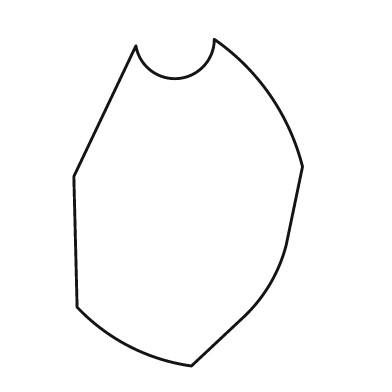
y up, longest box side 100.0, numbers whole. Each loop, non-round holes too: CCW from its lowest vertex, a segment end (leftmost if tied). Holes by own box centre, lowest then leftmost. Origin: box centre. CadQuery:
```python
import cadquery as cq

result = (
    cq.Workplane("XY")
    .moveTo(1.0, -50.0)
    .lineTo(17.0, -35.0)
    .threePointArc((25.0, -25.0), (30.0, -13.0))
    .lineTo(35.0, 11.0)
    .threePointArc((25.0, 33.0), (8.0, 50.0))
    .threePointArc((-3.0, 38.0), (-16.0, 48.0))
    .lineTo(-35.0, 8.0)
    .lineTo(-34.0, -32.0)
    .threePointArc((-18.0, -44.0), (1.0, -50.0))
    .close()
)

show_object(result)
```